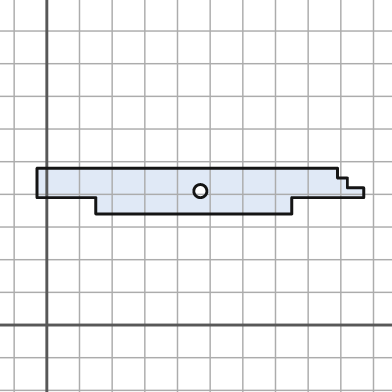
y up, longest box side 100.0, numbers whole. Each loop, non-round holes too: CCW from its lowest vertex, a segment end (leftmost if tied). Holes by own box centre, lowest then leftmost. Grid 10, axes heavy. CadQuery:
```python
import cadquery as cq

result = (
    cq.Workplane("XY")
    .moveTo(15.0, 34.0)
    .lineTo(75.0, 34.0)
    .lineTo(75.0, 39.0)
    .lineTo(97.0, 39.0)
    .lineTo(97.0, 42.0)
    .lineTo(92.0, 42.0)
    .lineTo(92.0, 45.0)
    .lineTo(89.0, 45.0)
    .lineTo(89.0, 48.0)
    .lineTo(-3.0, 48.0)
    .lineTo(-3.0, 39.0)
    .lineTo(15.0, 39.0)
    .close()
    .moveTo(47.0, 41.0)
    .circle(2.0)
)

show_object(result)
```